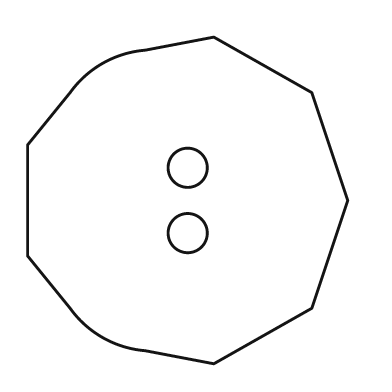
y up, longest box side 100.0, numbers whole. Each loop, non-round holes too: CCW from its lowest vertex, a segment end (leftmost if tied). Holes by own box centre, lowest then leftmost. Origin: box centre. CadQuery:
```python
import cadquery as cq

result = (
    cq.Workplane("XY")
    .moveTo(8.0, -50.0)
    .lineTo(38.0, -33.0)
    .lineTo(49.0, 0.0)
    .lineTo(38.0, 33.0)
    .lineTo(8.0, 50.0)
    .lineTo(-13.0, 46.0)
    .threePointArc((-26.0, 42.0), (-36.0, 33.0))
    .lineTo(-49.0, 17.0)
    .lineTo(-49.0, -17.0)
    .lineTo(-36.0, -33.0)
    .threePointArc((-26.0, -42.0), (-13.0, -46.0))
    .close()
    .moveTo(0.0, -10.0)
    .circle(6.0)
    .moveTo(0.0, 10.0)
    .circle(6.0)
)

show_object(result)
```